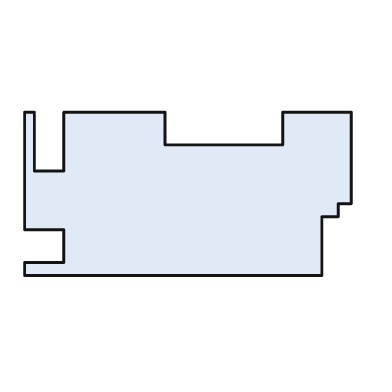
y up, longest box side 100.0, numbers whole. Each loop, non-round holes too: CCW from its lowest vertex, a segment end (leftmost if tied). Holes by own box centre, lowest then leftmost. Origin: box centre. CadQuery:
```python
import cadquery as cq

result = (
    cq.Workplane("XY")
    .moveTo(-50.0, -25.0)
    .lineTo(41.0, -25.0)
    .lineTo(41.0, -7.0)
    .lineTo(46.0, -7.0)
    .lineTo(46.0, -3.0)
    .lineTo(50.0, -3.0)
    .lineTo(50.0, 25.0)
    .lineTo(29.0, 25.0)
    .lineTo(29.0, 15.0)
    .lineTo(-7.0, 15.0)
    .lineTo(-7.0, 25.0)
    .lineTo(-38.0, 25.0)
    .lineTo(-38.0, 7.0)
    .lineTo(-47.0, 7.0)
    .lineTo(-47.0, 25.0)
    .lineTo(-50.0, 25.0)
    .lineTo(-50.0, -11.0)
    .lineTo(-38.0, -11.0)
    .lineTo(-38.0, -21.0)
    .lineTo(-50.0, -21.0)
    .close()
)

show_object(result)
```